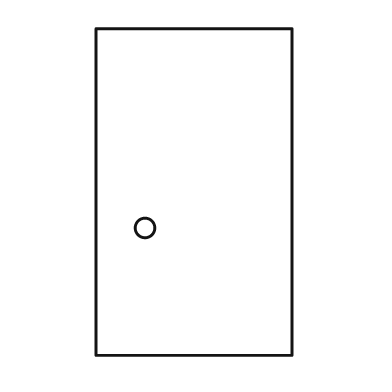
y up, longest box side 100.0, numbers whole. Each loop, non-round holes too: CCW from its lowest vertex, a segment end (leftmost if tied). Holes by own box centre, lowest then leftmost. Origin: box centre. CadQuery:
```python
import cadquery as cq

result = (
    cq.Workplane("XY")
    .moveTo(-30.0, -50.0)
    .lineTo(30.0, -50.0)
    .lineTo(30.0, 50.0)
    .lineTo(-30.0, 50.0)
    .close()
    .moveTo(-15.0, -11.0)
    .circle(3.0)
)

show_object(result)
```